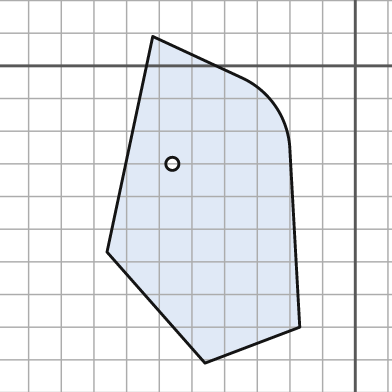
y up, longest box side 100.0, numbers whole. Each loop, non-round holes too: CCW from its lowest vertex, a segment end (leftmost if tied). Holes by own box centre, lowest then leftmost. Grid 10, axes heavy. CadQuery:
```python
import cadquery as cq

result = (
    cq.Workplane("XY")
    .moveTo(-46.0, -91.0)
    .lineTo(-17.0, -80.0)
    .lineTo(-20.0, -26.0)
    .threePointArc((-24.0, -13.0), (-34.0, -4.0))
    .lineTo(-62.0, 9.0)
    .lineTo(-76.0, -57.0)
    .close()
    .moveTo(-56.0, -30.0)
    .circle(2.0)
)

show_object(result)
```